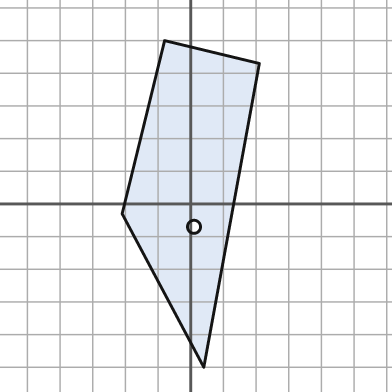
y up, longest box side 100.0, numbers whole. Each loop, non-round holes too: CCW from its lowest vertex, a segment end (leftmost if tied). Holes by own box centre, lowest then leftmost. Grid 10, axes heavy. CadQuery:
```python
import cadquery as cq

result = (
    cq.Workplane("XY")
    .moveTo(4.0, -50.0)
    .lineTo(21.0, 43.0)
    .lineTo(-8.0, 50.0)
    .lineTo(-21.0, -3.0)
    .close()
    .moveTo(1.0, -7.0)
    .circle(2.0)
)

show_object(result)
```